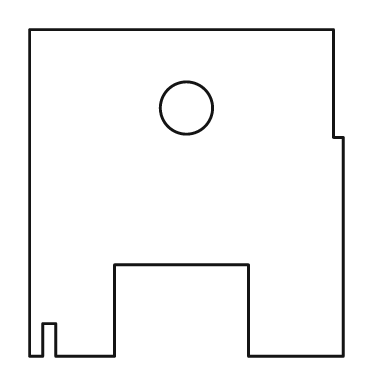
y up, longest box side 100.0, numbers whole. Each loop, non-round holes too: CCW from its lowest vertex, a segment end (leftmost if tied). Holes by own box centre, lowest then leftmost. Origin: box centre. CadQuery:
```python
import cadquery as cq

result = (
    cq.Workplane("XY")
    .moveTo(-48.0, -50.0)
    .lineTo(-44.0, -50.0)
    .lineTo(-44.0, -40.0)
    .lineTo(-40.0, -40.0)
    .lineTo(-40.0, -50.0)
    .lineTo(-22.0, -50.0)
    .lineTo(-22.0, -22.0)
    .lineTo(19.0, -22.0)
    .lineTo(19.0, -50.0)
    .lineTo(48.0, -50.0)
    .lineTo(48.0, 17.0)
    .lineTo(45.0, 17.0)
    .lineTo(45.0, 50.0)
    .lineTo(-48.0, 50.0)
    .close()
    .moveTo(0.0, 26.0)
    .circle(8.0)
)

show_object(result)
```